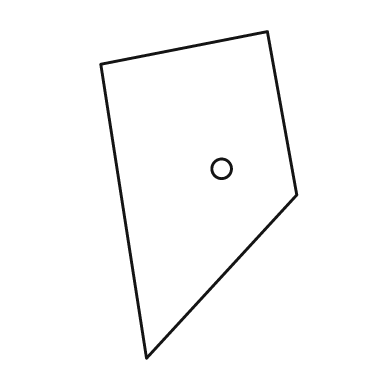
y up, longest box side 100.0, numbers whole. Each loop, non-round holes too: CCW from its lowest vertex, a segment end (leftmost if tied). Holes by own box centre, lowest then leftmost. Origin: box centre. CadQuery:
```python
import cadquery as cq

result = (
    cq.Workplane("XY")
    .moveTo(-16.0, -50.0)
    .lineTo(30.0, 0.0)
    .lineTo(21.0, 50.0)
    .lineTo(-30.0, 40.0)
    .close()
    .moveTo(7.0, 8.0)
    .circle(3.0)
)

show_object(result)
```